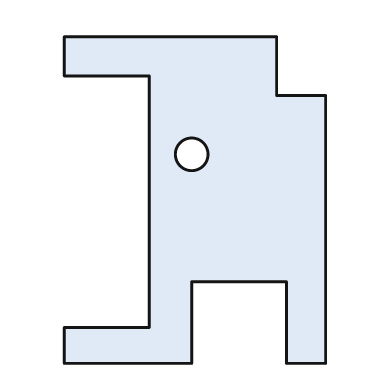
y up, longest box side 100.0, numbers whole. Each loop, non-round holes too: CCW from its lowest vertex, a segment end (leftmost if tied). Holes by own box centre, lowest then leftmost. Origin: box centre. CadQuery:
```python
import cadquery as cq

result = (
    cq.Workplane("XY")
    .moveTo(-40.0, -50.0)
    .lineTo(-1.0, -50.0)
    .lineTo(-1.0, -25.0)
    .lineTo(28.0, -25.0)
    .lineTo(28.0, -50.0)
    .lineTo(40.0, -50.0)
    .lineTo(40.0, 32.0)
    .lineTo(25.0, 32.0)
    .lineTo(25.0, 50.0)
    .lineTo(-40.0, 50.0)
    .lineTo(-40.0, 38.0)
    .lineTo(-14.0, 38.0)
    .lineTo(-14.0, -39.0)
    .lineTo(-40.0, -39.0)
    .close()
    .moveTo(-1.0, 14.0)
    .circle(5.0)
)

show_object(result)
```